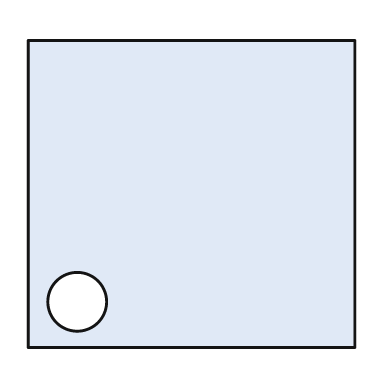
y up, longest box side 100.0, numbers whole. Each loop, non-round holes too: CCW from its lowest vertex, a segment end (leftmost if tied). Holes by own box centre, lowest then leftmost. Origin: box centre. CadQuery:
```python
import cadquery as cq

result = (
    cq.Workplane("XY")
    .moveTo(-50.0, -47.0)
    .lineTo(50.0, -47.0)
    .lineTo(50.0, 47.0)
    .lineTo(-50.0, 47.0)
    .close()
    .moveTo(-35.0, -33.0)
    .circle(9.0)
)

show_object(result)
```